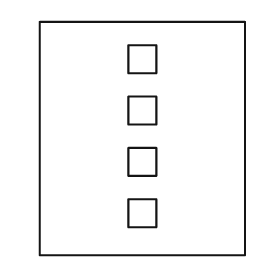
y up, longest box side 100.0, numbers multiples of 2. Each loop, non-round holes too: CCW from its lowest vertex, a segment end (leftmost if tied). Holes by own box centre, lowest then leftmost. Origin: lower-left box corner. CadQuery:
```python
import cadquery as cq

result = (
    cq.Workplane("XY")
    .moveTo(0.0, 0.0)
    .lineTo(88.0, 0.0)
    .lineTo(88.0, 100.0)
    .lineTo(0.0, 100.0)
    .close()
    .moveTo(38.0, 12.0)
    .lineTo(50.0, 12.0)
    .lineTo(50.0, 24.0)
    .lineTo(38.0, 24.0)
    .close()
    .moveTo(38.0, 34.0)
    .lineTo(50.0, 34.0)
    .lineTo(50.0, 46.0)
    .lineTo(38.0, 46.0)
    .close()
    .moveTo(38.0, 56.0)
    .lineTo(50.0, 56.0)
    .lineTo(50.0, 68.0)
    .lineTo(38.0, 68.0)
    .close()
    .moveTo(38.0, 78.0)
    .lineTo(50.0, 78.0)
    .lineTo(50.0, 90.0)
    .lineTo(38.0, 90.0)
    .close()
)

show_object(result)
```